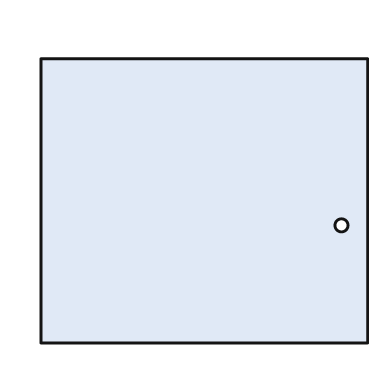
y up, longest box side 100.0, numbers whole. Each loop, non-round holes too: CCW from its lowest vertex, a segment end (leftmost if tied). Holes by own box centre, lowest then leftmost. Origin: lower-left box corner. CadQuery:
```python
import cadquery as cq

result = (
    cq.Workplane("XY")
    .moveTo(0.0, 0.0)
    .lineTo(100.0, 0.0)
    .lineTo(100.0, 87.0)
    .lineTo(0.0, 87.0)
    .close()
    .moveTo(92.0, 36.0)
    .circle(2.0)
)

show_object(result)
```